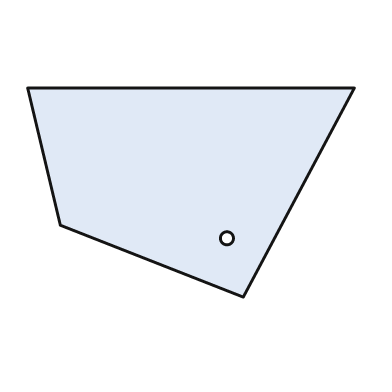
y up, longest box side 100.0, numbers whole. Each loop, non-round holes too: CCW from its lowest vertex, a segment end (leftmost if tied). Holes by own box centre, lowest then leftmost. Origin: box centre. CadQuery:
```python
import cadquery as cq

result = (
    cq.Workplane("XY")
    .moveTo(16.0, -32.0)
    .lineTo(50.0, 32.0)
    .lineTo(-50.0, 32.0)
    .lineTo(-40.0, -10.0)
    .close()
    .moveTo(11.0, -14.0)
    .circle(2.0)
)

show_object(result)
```